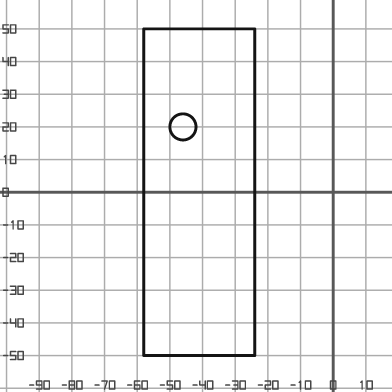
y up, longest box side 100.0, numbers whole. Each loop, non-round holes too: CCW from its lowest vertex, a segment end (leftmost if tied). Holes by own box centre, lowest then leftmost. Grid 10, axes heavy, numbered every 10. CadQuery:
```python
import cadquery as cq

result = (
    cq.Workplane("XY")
    .moveTo(-58.0, -50.0)
    .lineTo(-24.0, -50.0)
    .lineTo(-24.0, 50.0)
    .lineTo(-58.0, 50.0)
    .close()
    .moveTo(-46.0, 20.0)
    .circle(4.0)
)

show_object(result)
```